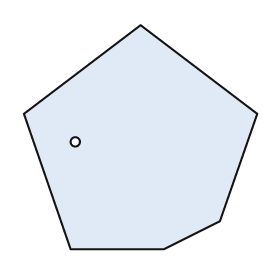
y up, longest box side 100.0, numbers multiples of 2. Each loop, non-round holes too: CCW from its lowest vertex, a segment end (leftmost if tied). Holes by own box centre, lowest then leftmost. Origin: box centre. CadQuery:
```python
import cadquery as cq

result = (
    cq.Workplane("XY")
    .moveTo(-30.0, -48.0)
    .lineTo(10.0, -48.0)
    .lineTo(34.0, -36.0)
    .lineTo(50.0, 10.0)
    .lineTo(0.0, 48.0)
    .lineTo(-50.0, 10.0)
    .close()
    .moveTo(-28.0, -2.0)
    .circle(2.0)
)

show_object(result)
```